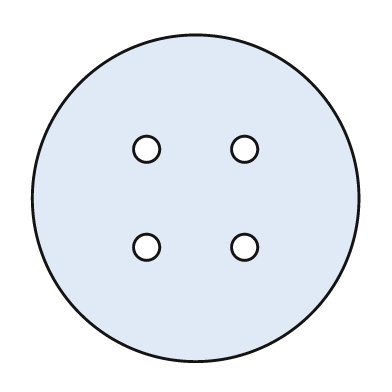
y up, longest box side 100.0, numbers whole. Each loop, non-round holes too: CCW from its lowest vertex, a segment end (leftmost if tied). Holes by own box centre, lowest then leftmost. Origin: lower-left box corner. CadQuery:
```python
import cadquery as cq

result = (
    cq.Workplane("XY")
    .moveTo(50.0, 50.0)
    .circle(50.0)
    .moveTo(35.0, 35.0)
    .circle(4.0)
    .moveTo(65.0, 35.0)
    .circle(4.0)
    .moveTo(35.0, 65.0)
    .circle(4.0)
    .moveTo(65.0, 65.0)
    .circle(4.0)
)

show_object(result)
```